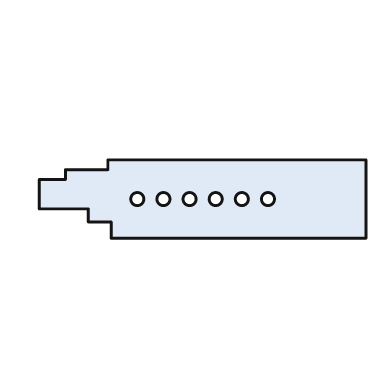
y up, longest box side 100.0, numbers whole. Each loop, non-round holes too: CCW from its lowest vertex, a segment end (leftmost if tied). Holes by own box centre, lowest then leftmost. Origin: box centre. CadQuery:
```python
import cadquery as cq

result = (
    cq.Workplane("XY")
    .moveTo(-28.0, -12.0)
    .lineTo(50.0, -12.0)
    .lineTo(50.0, 12.0)
    .lineTo(-29.0, 12.0)
    .lineTo(-29.0, 9.0)
    .lineTo(-42.0, 9.0)
    .lineTo(-42.0, 6.0)
    .lineTo(-50.0, 6.0)
    .lineTo(-50.0, -3.0)
    .lineTo(-35.0, -3.0)
    .lineTo(-35.0, -7.0)
    .lineTo(-28.0, -7.0)
    .close()
    .moveTo(-20.0, 0.0)
    .circle(2.0)
    .moveTo(-12.0, 0.0)
    .circle(2.0)
    .moveTo(-4.0, 0.0)
    .circle(2.0)
    .moveTo(4.0, 0.0)
    .circle(2.0)
    .moveTo(12.0, 0.0)
    .circle(2.0)
    .moveTo(20.0, 0.0)
    .circle(2.0)
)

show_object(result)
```